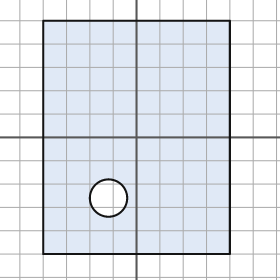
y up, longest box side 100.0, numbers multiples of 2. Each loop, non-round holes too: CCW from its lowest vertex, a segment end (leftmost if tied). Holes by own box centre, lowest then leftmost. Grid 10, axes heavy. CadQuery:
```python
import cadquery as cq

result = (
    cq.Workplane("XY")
    .moveTo(-40.0, -50.0)
    .lineTo(40.0, -50.0)
    .lineTo(40.0, 50.0)
    .lineTo(-40.0, 50.0)
    .close()
    .moveTo(-12.0, -26.0)
    .circle(8.0)
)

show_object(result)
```